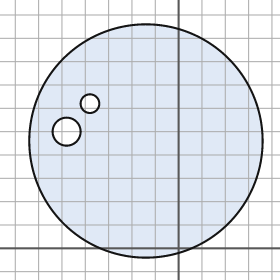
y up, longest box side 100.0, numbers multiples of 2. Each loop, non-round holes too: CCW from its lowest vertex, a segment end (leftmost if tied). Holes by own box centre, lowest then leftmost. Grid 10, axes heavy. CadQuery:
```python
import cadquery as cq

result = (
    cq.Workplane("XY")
    .moveTo(-14.0, 46.0)
    .circle(50.0)
    .moveTo(-48.0, 50.0)
    .circle(6.0)
    .moveTo(-38.0, 62.0)
    .circle(4.0)
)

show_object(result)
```